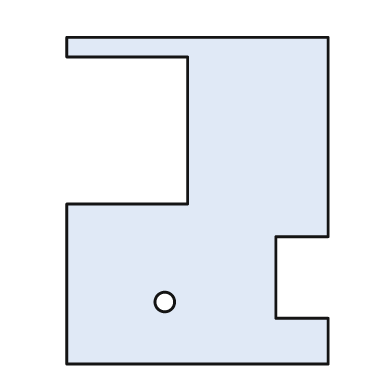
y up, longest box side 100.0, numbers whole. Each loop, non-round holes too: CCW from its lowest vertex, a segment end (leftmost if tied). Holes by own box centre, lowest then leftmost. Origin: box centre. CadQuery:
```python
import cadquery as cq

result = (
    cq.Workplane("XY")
    .moveTo(-40.0, -50.0)
    .lineTo(40.0, -50.0)
    .lineTo(40.0, -36.0)
    .lineTo(24.0, -36.0)
    .lineTo(24.0, -11.0)
    .lineTo(40.0, -11.0)
    .lineTo(40.0, 50.0)
    .lineTo(-40.0, 50.0)
    .lineTo(-40.0, 44.0)
    .lineTo(-3.0, 44.0)
    .lineTo(-3.0, -1.0)
    .lineTo(-40.0, -1.0)
    .close()
    .moveTo(-10.0, -31.0)
    .circle(3.0)
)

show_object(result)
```